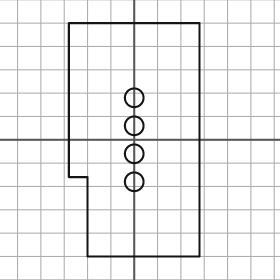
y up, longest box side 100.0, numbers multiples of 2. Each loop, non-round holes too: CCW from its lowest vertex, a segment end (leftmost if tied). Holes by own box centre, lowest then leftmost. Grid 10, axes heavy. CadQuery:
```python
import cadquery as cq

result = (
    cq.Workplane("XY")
    .moveTo(-20.0, -50.0)
    .lineTo(28.0, -50.0)
    .lineTo(28.0, 50.0)
    .lineTo(-28.0, 50.0)
    .lineTo(-28.0, -16.0)
    .lineTo(-20.0, -16.0)
    .close()
    .moveTo(0.0, -18.0)
    .circle(4.0)
    .moveTo(0.0, -6.0)
    .circle(4.0)
    .moveTo(0.0, 6.0)
    .circle(4.0)
    .moveTo(0.0, 18.0)
    .circle(4.0)
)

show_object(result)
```